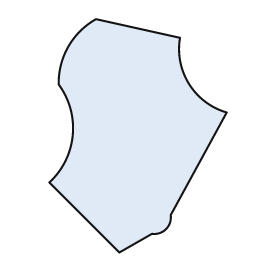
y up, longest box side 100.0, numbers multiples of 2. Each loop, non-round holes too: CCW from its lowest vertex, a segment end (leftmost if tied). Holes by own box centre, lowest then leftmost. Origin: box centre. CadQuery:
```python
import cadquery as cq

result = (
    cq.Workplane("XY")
    .moveTo(-8.0, -50.0)
    .lineTo(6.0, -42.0)
    .threePointArc((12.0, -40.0), (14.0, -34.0))
    .lineTo(38.0, 10.0)
    .threePointArc((22.0, 22.0), (18.0, 42.0))
    .lineTo(-18.0, 50.0)
    .threePointArc((-30.0, 38.0), (-34.0, 22.0))
    .threePointArc((-28.0, 0.0), (-38.0, -20.0))
    .close()
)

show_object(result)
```